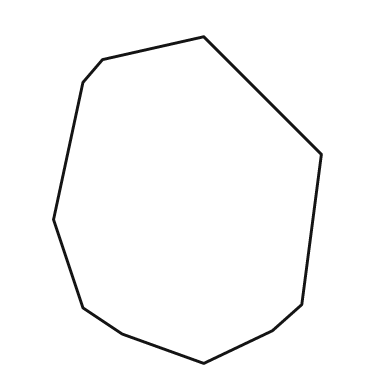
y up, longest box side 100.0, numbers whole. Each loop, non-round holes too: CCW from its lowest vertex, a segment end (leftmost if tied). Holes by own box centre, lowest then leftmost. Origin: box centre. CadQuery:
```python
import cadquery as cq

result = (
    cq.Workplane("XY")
    .moveTo(5.0, -50.0)
    .lineTo(26.0, -40.0)
    .lineTo(35.0, -32.0)
    .lineTo(41.0, 14.0)
    .lineTo(5.0, 50.0)
    .lineTo(-26.0, 43.0)
    .lineTo(-32.0, 36.0)
    .lineTo(-41.0, -6.0)
    .lineTo(-32.0, -33.0)
    .lineTo(-20.0, -41.0)
    .close()
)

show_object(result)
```